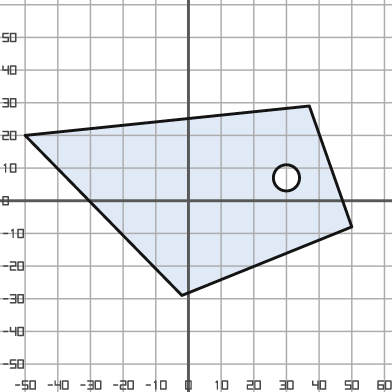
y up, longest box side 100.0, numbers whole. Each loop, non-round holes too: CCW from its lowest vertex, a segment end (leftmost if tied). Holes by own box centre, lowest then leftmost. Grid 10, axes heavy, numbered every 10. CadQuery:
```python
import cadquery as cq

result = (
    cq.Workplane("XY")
    .moveTo(-2.0, -29.0)
    .lineTo(50.0, -8.0)
    .lineTo(37.0, 29.0)
    .lineTo(-50.0, 20.0)
    .close()
    .moveTo(30.0, 7.0)
    .circle(4.0)
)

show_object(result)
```